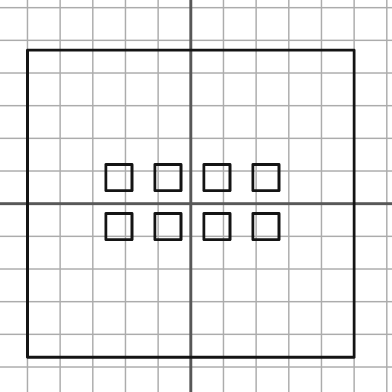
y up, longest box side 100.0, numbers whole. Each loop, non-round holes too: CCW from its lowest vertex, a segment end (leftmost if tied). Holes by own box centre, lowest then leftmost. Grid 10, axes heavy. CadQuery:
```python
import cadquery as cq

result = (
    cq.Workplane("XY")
    .moveTo(-50.0, -47.0)
    .lineTo(50.0, -47.0)
    .lineTo(50.0, 47.0)
    .lineTo(-50.0, 47.0)
    .close()
    .moveTo(-26.0, -11.0)
    .lineTo(-18.0, -11.0)
    .lineTo(-18.0, -3.0)
    .lineTo(-26.0, -3.0)
    .close()
    .moveTo(-11.0, -11.0)
    .lineTo(-3.0, -11.0)
    .lineTo(-3.0, -3.0)
    .lineTo(-11.0, -3.0)
    .close()
    .moveTo(4.0, -11.0)
    .lineTo(12.0, -11.0)
    .lineTo(12.0, -3.0)
    .lineTo(4.0, -3.0)
    .close()
    .moveTo(19.0, -11.0)
    .lineTo(27.0, -11.0)
    .lineTo(27.0, -3.0)
    .lineTo(19.0, -3.0)
    .close()
    .moveTo(-26.0, 4.0)
    .lineTo(-18.0, 4.0)
    .lineTo(-18.0, 12.0)
    .lineTo(-26.0, 12.0)
    .close()
    .moveTo(-11.0, 4.0)
    .lineTo(-3.0, 4.0)
    .lineTo(-3.0, 12.0)
    .lineTo(-11.0, 12.0)
    .close()
    .moveTo(4.0, 4.0)
    .lineTo(12.0, 4.0)
    .lineTo(12.0, 12.0)
    .lineTo(4.0, 12.0)
    .close()
    .moveTo(19.0, 4.0)
    .lineTo(27.0, 4.0)
    .lineTo(27.0, 12.0)
    .lineTo(19.0, 12.0)
    .close()
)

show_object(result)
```